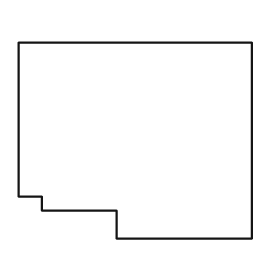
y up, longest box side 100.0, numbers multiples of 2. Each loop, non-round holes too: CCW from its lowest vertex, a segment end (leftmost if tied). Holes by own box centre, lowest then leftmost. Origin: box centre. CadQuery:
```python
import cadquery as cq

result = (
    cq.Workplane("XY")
    .moveTo(-8.0, -42.0)
    .lineTo(50.0, -42.0)
    .lineTo(50.0, 42.0)
    .lineTo(-50.0, 42.0)
    .lineTo(-50.0, -24.0)
    .lineTo(-40.0, -24.0)
    .lineTo(-40.0, -30.0)
    .lineTo(-8.0, -30.0)
    .close()
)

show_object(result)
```